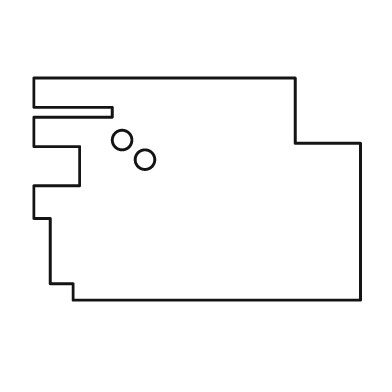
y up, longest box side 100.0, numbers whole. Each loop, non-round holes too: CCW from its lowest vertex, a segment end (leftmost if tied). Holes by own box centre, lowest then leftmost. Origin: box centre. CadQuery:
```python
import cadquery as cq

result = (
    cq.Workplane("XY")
    .moveTo(-38.0, -34.0)
    .lineTo(50.0, -34.0)
    .lineTo(50.0, 14.0)
    .lineTo(30.0, 14.0)
    .lineTo(30.0, 34.0)
    .lineTo(-50.0, 34.0)
    .lineTo(-50.0, 25.0)
    .lineTo(-26.0, 25.0)
    .lineTo(-26.0, 22.0)
    .lineTo(-50.0, 22.0)
    .lineTo(-50.0, 13.0)
    .lineTo(-36.0, 13.0)
    .lineTo(-36.0, 1.0)
    .lineTo(-50.0, 1.0)
    .lineTo(-50.0, -9.0)
    .lineTo(-45.0, -9.0)
    .lineTo(-45.0, -29.0)
    .lineTo(-38.0, -29.0)
    .close()
    .moveTo(-16.0, 9.0)
    .circle(3.0)
    .moveTo(-23.0, 15.0)
    .circle(3.0)
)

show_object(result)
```